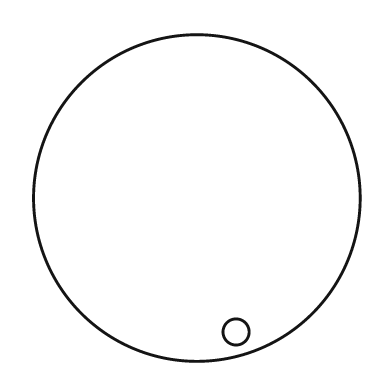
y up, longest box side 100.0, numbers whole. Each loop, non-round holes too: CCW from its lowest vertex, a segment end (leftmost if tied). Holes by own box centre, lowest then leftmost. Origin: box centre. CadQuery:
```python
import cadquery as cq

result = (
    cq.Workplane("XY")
    .moveTo(0.0, 0.0)
    .circle(50.0)
    .moveTo(12.0, -41.0)
    .circle(4.0)
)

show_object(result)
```